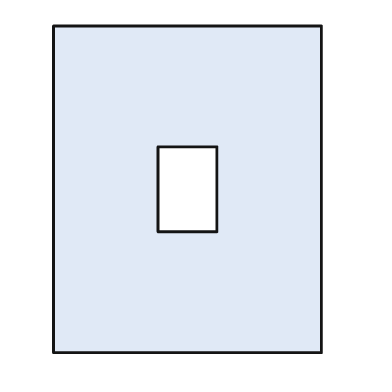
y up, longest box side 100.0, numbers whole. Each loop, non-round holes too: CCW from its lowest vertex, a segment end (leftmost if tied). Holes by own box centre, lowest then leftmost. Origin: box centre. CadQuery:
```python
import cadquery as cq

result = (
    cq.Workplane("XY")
    .moveTo(-41.0, -50.0)
    .lineTo(41.0, -50.0)
    .lineTo(41.0, 50.0)
    .lineTo(-41.0, 50.0)
    .close()
    .moveTo(-9.0, -13.0)
    .lineTo(9.0, -13.0)
    .lineTo(9.0, 13.0)
    .lineTo(-9.0, 13.0)
    .close()
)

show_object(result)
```